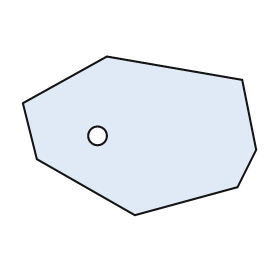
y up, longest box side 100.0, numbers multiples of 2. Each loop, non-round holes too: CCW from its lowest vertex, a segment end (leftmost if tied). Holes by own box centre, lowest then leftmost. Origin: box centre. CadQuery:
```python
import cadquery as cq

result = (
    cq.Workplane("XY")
    .moveTo(-2.0, -34.0)
    .lineTo(42.0, -22.0)
    .lineTo(50.0, -6.0)
    .lineTo(44.0, 24.0)
    .lineTo(-14.0, 34.0)
    .lineTo(-50.0, 14.0)
    .lineTo(-44.0, -10.0)
    .close()
    .moveTo(-18.0, 0.0)
    .circle(4.0)
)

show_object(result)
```